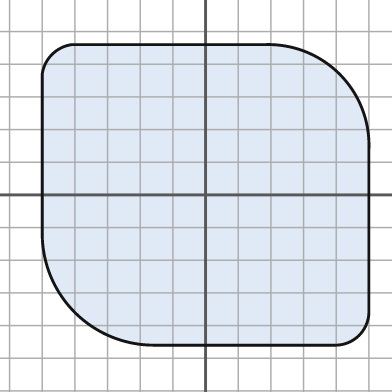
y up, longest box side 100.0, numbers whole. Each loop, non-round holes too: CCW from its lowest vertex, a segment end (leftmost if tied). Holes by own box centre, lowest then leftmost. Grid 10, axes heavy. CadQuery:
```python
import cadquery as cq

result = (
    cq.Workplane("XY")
    .moveTo(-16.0, -46.0)
    .lineTo(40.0, -46.0)
    .threePointArc((47.0, -43.0), (50.0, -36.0))
    .lineTo(50.0, 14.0)
    .threePointArc((41.0, 37.0), (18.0, 46.0))
    .lineTo(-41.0, 46.0)
    .threePointArc((-47.0, 43.0), (-50.0, 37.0))
    .lineTo(-50.0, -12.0)
    .threePointArc((-40.0, -36.0), (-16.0, -46.0))
    .close()
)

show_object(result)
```